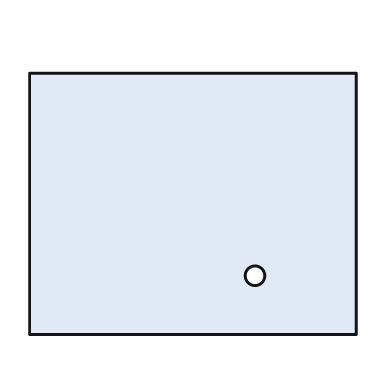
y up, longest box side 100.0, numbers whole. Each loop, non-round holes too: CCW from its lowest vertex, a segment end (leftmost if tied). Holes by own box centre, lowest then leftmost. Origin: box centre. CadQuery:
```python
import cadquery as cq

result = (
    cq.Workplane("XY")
    .moveTo(-50.0, -40.0)
    .lineTo(50.0, -40.0)
    .lineTo(50.0, 40.0)
    .lineTo(-50.0, 40.0)
    .close()
    .moveTo(19.0, -22.0)
    .circle(3.0)
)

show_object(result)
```